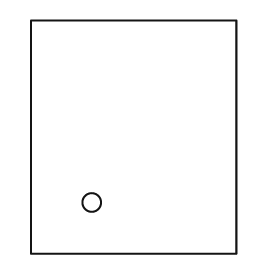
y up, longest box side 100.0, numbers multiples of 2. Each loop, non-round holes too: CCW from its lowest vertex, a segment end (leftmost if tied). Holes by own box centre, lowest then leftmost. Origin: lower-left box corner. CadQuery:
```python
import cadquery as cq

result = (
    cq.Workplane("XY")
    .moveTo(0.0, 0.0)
    .lineTo(88.0, 0.0)
    .lineTo(88.0, 100.0)
    .lineTo(0.0, 100.0)
    .close()
    .moveTo(26.0, 22.0)
    .circle(4.0)
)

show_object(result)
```